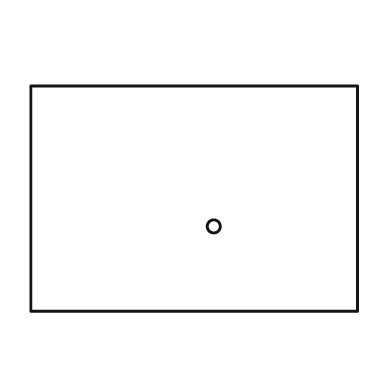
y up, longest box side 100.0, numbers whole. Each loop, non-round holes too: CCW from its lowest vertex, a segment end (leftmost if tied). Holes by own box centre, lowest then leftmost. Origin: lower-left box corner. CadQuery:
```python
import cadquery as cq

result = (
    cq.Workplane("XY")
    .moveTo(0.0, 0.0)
    .lineTo(100.0, 0.0)
    .lineTo(100.0, 69.0)
    .lineTo(0.0, 69.0)
    .close()
    .moveTo(56.0, 26.0)
    .circle(2.0)
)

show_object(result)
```